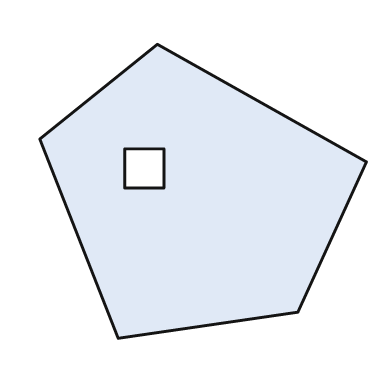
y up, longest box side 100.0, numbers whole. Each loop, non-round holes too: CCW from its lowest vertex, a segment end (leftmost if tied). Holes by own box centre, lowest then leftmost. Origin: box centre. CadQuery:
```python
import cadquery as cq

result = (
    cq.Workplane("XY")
    .moveTo(-26.0, -45.0)
    .lineTo(29.0, -37.0)
    .lineTo(50.0, 9.0)
    .lineTo(-14.0, 45.0)
    .lineTo(-50.0, 16.0)
    .close()
    .moveTo(-24.0, 1.0)
    .lineTo(-12.0, 1.0)
    .lineTo(-12.0, 13.0)
    .lineTo(-24.0, 13.0)
    .close()
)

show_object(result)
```